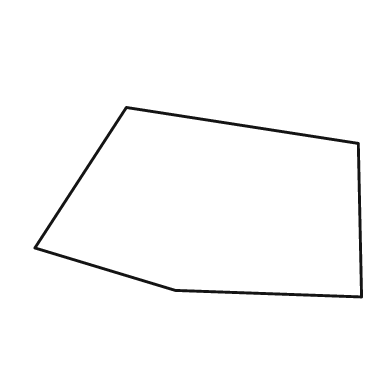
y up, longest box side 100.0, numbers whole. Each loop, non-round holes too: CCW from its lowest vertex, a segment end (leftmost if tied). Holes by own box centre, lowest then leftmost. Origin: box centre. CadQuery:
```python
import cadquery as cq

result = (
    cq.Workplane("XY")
    .moveTo(50.0, -29.0)
    .lineTo(49.0, 18.0)
    .lineTo(-22.0, 29.0)
    .lineTo(-50.0, -14.0)
    .lineTo(-7.0, -27.0)
    .close()
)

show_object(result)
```